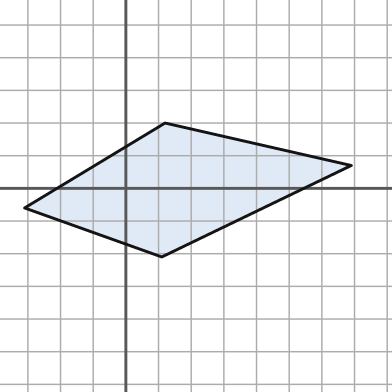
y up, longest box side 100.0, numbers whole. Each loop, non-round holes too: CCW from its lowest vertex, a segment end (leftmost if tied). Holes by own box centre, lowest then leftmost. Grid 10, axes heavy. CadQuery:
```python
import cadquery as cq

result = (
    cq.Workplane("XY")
    .moveTo(11.0, -21.0)
    .lineTo(69.0, 7.0)
    .lineTo(12.0, 20.0)
    .lineTo(-31.0, -6.0)
    .close()
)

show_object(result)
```